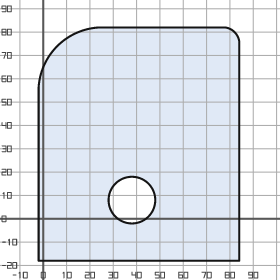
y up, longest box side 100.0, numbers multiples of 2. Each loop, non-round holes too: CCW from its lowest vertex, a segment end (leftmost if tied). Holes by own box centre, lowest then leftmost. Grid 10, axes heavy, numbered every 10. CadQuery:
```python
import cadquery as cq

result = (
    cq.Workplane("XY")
    .moveTo(-2.0, -18.0)
    .lineTo(84.0, -18.0)
    .lineTo(84.0, 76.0)
    .threePointArc((82.0, 80.0), (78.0, 82.0))
    .lineTo(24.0, 82.0)
    .threePointArc((6.0, 74.0), (-2.0, 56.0))
    .close()
    .moveTo(38.0, 8.0)
    .circle(10.0)
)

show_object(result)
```